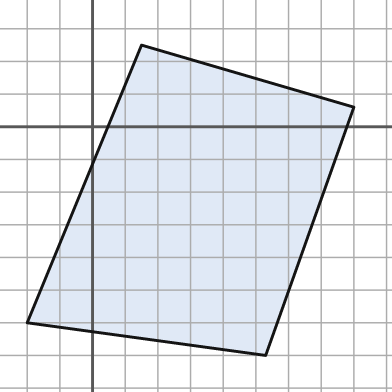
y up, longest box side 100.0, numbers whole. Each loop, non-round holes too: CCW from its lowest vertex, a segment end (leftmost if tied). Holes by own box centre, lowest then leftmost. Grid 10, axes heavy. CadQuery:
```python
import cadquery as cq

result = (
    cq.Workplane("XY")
    .moveTo(53.0, -70.0)
    .lineTo(80.0, 6.0)
    .lineTo(15.0, 25.0)
    .lineTo(-20.0, -60.0)
    .close()
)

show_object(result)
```